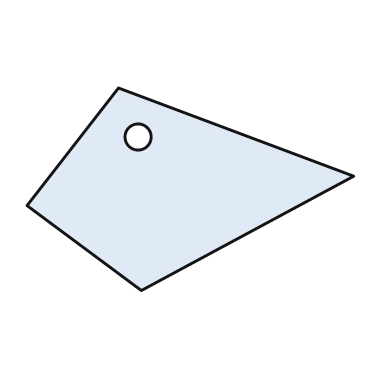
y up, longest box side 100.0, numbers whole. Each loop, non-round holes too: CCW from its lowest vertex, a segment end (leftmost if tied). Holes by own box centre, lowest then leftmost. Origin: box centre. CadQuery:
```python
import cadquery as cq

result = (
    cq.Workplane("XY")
    .moveTo(-15.0, -31.0)
    .lineTo(50.0, 4.0)
    .lineTo(-22.0, 31.0)
    .lineTo(-50.0, -5.0)
    .close()
    .moveTo(-16.0, 16.0)
    .circle(4.0)
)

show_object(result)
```